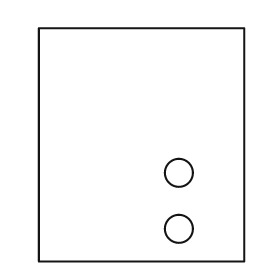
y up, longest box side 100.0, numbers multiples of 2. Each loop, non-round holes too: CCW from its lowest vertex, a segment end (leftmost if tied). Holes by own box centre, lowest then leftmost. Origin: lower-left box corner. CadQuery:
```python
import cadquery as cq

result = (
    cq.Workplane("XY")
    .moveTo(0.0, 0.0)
    .lineTo(88.0, 0.0)
    .lineTo(88.0, 100.0)
    .lineTo(0.0, 100.0)
    .close()
    .moveTo(60.0, 14.0)
    .circle(6.0)
    .moveTo(60.0, 38.0)
    .circle(6.0)
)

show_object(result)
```